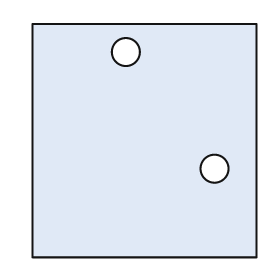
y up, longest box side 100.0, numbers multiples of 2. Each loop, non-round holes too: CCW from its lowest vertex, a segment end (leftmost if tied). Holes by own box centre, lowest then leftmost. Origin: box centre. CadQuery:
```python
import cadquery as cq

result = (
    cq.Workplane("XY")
    .moveTo(-48.0, -50.0)
    .lineTo(48.0, -50.0)
    .lineTo(48.0, 50.0)
    .lineTo(-48.0, 50.0)
    .close()
    .moveTo(30.0, -12.0)
    .circle(6.0)
    .moveTo(-8.0, 38.0)
    .circle(6.0)
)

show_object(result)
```